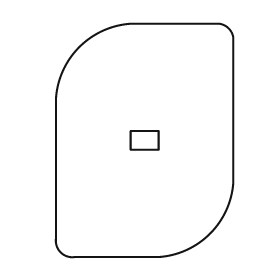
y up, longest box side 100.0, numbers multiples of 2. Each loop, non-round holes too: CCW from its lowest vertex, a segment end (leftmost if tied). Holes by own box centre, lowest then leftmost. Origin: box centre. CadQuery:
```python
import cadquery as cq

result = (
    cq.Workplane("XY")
    .moveTo(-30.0, -50.0)
    .lineTo(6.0, -50.0)
    .threePointArc((28.0, -40.0), (38.0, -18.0))
    .lineTo(38.0, 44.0)
    .threePointArc((36.0, 48.0), (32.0, 50.0))
    .lineTo(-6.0, 50.0)
    .threePointArc((-28.0, 40.0), (-38.0, 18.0))
    .lineTo(-38.0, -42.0)
    .threePointArc((-36.0, -48.0), (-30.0, -50.0))
    .close()
    .moveTo(-6.0, -4.0)
    .lineTo(6.0, -4.0)
    .lineTo(6.0, 4.0)
    .lineTo(-6.0, 4.0)
    .close()
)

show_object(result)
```